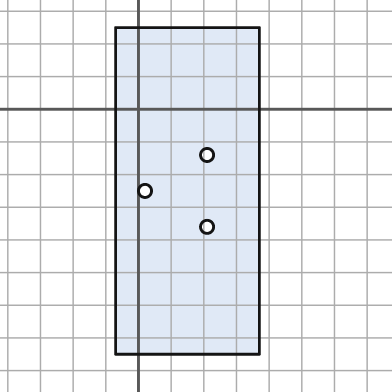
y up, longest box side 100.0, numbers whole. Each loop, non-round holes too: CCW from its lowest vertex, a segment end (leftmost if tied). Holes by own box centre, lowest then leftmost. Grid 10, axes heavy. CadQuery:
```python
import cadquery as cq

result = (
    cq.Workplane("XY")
    .moveTo(-7.0, -75.0)
    .lineTo(37.0, -75.0)
    .lineTo(37.0, 25.0)
    .lineTo(-7.0, 25.0)
    .close()
    .moveTo(21.0, -36.0)
    .circle(2.0)
    .moveTo(2.0, -25.0)
    .circle(2.0)
    .moveTo(21.0, -14.0)
    .circle(2.0)
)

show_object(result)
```